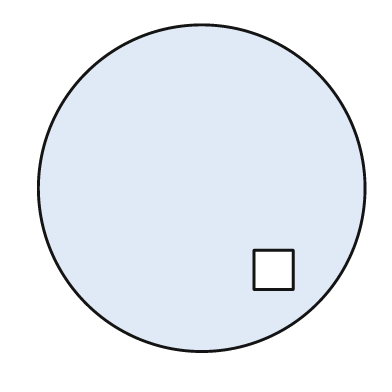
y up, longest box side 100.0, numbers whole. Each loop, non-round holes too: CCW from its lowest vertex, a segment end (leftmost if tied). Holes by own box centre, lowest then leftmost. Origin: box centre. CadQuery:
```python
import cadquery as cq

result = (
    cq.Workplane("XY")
    .moveTo(0.0, 0.0)
    .circle(50.0)
    .moveTo(16.0, -31.0)
    .lineTo(28.0, -31.0)
    .lineTo(28.0, -19.0)
    .lineTo(16.0, -19.0)
    .close()
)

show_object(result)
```